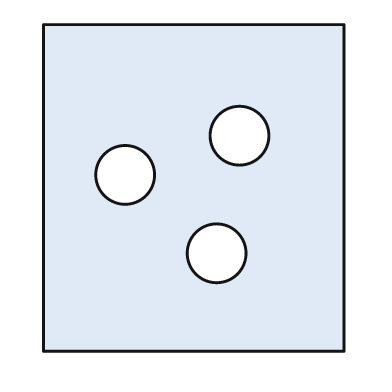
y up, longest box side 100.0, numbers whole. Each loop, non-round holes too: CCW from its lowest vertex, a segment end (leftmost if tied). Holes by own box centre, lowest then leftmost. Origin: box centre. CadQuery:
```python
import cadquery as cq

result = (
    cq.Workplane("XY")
    .moveTo(-46.0, -50.0)
    .lineTo(46.0, -50.0)
    .lineTo(46.0, 50.0)
    .lineTo(-46.0, 50.0)
    .close()
    .moveTo(7.0, -20.0)
    .circle(9.0)
    .moveTo(-21.0, 4.0)
    .circle(9.0)
    .moveTo(14.0, 16.0)
    .circle(9.0)
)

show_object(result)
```